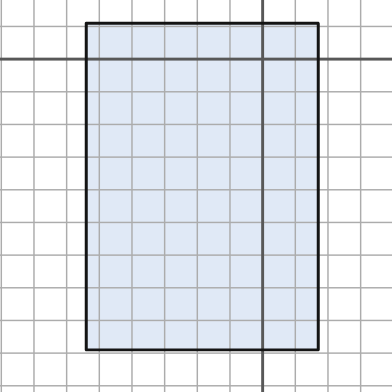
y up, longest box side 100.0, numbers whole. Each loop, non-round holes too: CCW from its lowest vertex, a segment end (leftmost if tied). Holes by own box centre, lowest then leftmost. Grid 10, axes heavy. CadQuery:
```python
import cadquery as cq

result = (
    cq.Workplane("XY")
    .moveTo(-54.0, -89.0)
    .lineTo(17.0, -89.0)
    .lineTo(17.0, 11.0)
    .lineTo(-54.0, 11.0)
    .close()
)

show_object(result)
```